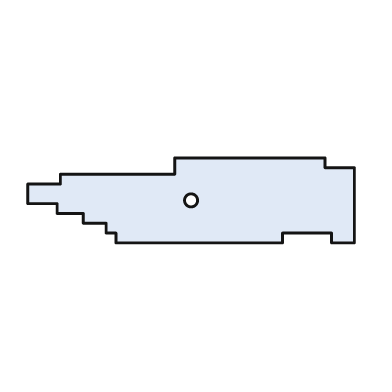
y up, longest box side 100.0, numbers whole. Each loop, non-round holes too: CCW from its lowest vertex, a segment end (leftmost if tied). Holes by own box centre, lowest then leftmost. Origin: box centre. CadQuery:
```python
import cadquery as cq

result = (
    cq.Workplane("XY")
    .moveTo(-23.0, -13.0)
    .lineTo(28.0, -13.0)
    .lineTo(28.0, -10.0)
    .lineTo(43.0, -10.0)
    .lineTo(43.0, -13.0)
    .lineTo(50.0, -13.0)
    .lineTo(50.0, 10.0)
    .lineTo(41.0, 10.0)
    .lineTo(41.0, 13.0)
    .lineTo(-5.0, 13.0)
    .lineTo(-5.0, 8.0)
    .lineTo(-40.0, 8.0)
    .lineTo(-40.0, 5.0)
    .lineTo(-50.0, 5.0)
    .lineTo(-50.0, -1.0)
    .lineTo(-41.0, -1.0)
    .lineTo(-41.0, -4.0)
    .lineTo(-33.0, -4.0)
    .lineTo(-33.0, -7.0)
    .lineTo(-26.0, -7.0)
    .lineTo(-26.0, -10.0)
    .lineTo(-23.0, -10.0)
    .close()
    .moveTo(0.0, 0.0)
    .circle(2.0)
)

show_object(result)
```